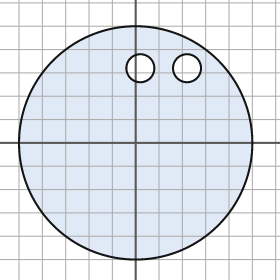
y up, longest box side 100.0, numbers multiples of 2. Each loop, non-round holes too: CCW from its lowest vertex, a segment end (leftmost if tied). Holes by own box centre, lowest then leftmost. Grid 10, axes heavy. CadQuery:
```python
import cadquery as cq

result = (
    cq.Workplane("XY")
    .moveTo(0.0, 0.0)
    .circle(50.0)
    .moveTo(2.0, 32.0)
    .circle(6.0)
    .moveTo(22.0, 32.0)
    .circle(6.0)
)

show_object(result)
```